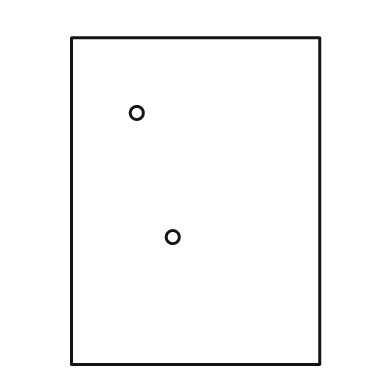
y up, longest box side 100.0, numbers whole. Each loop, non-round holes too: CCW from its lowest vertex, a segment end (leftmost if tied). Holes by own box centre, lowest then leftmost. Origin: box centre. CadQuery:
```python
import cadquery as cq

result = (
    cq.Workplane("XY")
    .moveTo(-38.0, -50.0)
    .lineTo(38.0, -50.0)
    .lineTo(38.0, 50.0)
    .lineTo(-38.0, 50.0)
    .close()
    .moveTo(-7.0, -11.0)
    .circle(2.0)
    .moveTo(-18.0, 27.0)
    .circle(2.0)
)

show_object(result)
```